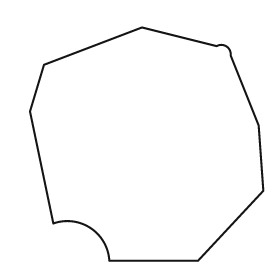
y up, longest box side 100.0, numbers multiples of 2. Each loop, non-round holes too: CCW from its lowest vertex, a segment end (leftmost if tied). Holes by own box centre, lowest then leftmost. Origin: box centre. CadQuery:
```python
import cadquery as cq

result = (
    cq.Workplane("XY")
    .moveTo(-16.0, -50.0)
    .lineTo(22.0, -50.0)
    .lineTo(50.0, -20.0)
    .lineTo(48.0, 8.0)
    .lineTo(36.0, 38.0)
    .threePointArc((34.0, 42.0), (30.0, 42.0))
    .lineTo(-2.0, 50.0)
    .lineTo(-44.0, 34.0)
    .lineTo(-50.0, 14.0)
    .lineTo(-40.0, -34.0)
    .threePointArc((-24.0, -36.0), (-16.0, -50.0))
    .close()
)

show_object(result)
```